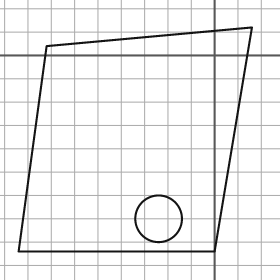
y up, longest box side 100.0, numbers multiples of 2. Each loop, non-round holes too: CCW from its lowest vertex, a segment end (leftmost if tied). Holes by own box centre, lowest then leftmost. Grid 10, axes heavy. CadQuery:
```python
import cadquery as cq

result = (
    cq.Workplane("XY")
    .moveTo(-84.0, -84.0)
    .lineTo(0.0, -84.0)
    .lineTo(16.0, 12.0)
    .lineTo(-72.0, 4.0)
    .close()
    .moveTo(-24.0, -70.0)
    .circle(10.0)
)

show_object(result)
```